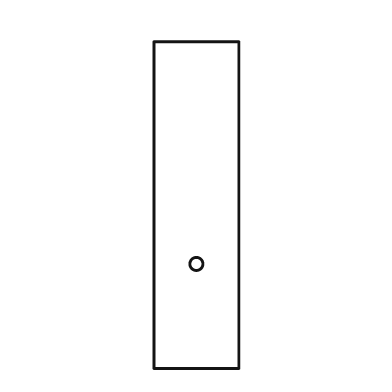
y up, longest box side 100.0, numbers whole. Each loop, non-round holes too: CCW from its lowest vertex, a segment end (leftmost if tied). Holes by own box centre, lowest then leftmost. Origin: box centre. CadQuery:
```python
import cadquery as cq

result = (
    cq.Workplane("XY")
    .moveTo(-13.0, -50.0)
    .lineTo(13.0, -50.0)
    .lineTo(13.0, 50.0)
    .lineTo(-13.0, 50.0)
    .close()
    .moveTo(0.0, -18.0)
    .circle(2.0)
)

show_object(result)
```